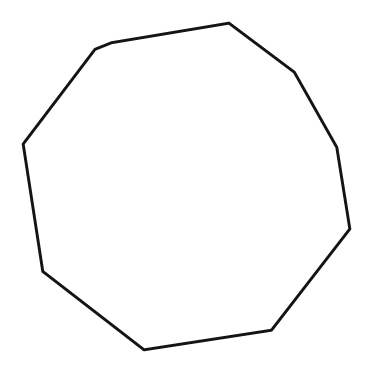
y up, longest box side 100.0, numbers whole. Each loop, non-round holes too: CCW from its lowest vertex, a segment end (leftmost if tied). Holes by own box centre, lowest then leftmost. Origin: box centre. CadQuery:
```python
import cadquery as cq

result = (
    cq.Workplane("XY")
    .moveTo(-13.0, -50.0)
    .lineTo(26.0, -44.0)
    .lineTo(50.0, -13.0)
    .lineTo(46.0, 12.0)
    .lineTo(33.0, 35.0)
    .lineTo(13.0, 50.0)
    .lineTo(-23.0, 44.0)
    .lineTo(-28.0, 42.0)
    .lineTo(-50.0, 13.0)
    .lineTo(-44.0, -26.0)
    .close()
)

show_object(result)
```